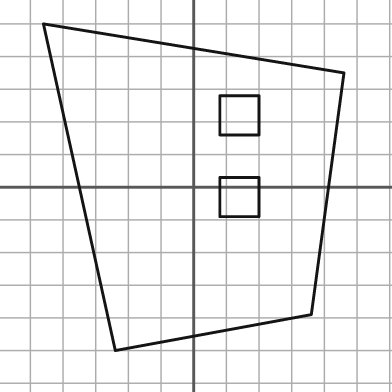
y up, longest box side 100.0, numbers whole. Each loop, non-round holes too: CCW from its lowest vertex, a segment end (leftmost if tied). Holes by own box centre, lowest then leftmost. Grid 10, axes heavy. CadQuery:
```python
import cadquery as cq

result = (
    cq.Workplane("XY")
    .moveTo(-24.0, -50.0)
    .lineTo(36.0, -39.0)
    .lineTo(46.0, 35.0)
    .lineTo(-46.0, 50.0)
    .close()
    .moveTo(8.0, -9.0)
    .lineTo(20.0, -9.0)
    .lineTo(20.0, 3.0)
    .lineTo(8.0, 3.0)
    .close()
    .moveTo(8.0, 16.0)
    .lineTo(20.0, 16.0)
    .lineTo(20.0, 28.0)
    .lineTo(8.0, 28.0)
    .close()
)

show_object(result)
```